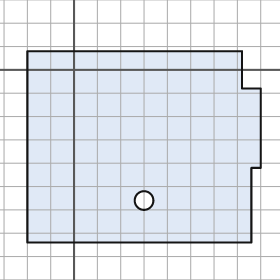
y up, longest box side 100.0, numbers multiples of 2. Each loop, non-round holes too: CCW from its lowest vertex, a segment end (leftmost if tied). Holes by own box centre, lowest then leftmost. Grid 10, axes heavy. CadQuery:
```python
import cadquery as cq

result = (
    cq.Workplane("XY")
    .moveTo(-20.0, -74.0)
    .lineTo(76.0, -74.0)
    .lineTo(76.0, -42.0)
    .lineTo(80.0, -42.0)
    .lineTo(80.0, -8.0)
    .lineTo(72.0, -8.0)
    .lineTo(72.0, 8.0)
    .lineTo(-20.0, 8.0)
    .close()
    .moveTo(30.0, -56.0)
    .circle(4.0)
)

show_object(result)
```